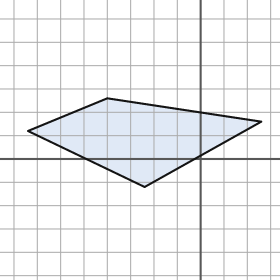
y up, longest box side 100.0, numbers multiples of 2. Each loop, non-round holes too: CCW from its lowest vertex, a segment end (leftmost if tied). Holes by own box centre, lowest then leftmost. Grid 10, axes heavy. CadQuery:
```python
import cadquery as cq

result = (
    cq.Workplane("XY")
    .moveTo(-24.0, -12.0)
    .lineTo(26.0, 16.0)
    .lineTo(-40.0, 26.0)
    .lineTo(-74.0, 12.0)
    .close()
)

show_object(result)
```